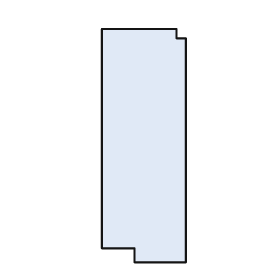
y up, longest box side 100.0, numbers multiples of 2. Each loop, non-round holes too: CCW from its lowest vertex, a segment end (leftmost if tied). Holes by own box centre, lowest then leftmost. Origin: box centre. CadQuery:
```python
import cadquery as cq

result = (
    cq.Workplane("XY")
    .moveTo(-4.0, -50.0)
    .lineTo(18.0, -50.0)
    .lineTo(18.0, 46.0)
    .lineTo(14.0, 46.0)
    .lineTo(14.0, 50.0)
    .lineTo(-18.0, 50.0)
    .lineTo(-18.0, -44.0)
    .lineTo(-4.0, -44.0)
    .close()
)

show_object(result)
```